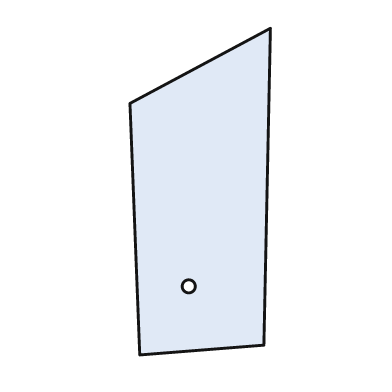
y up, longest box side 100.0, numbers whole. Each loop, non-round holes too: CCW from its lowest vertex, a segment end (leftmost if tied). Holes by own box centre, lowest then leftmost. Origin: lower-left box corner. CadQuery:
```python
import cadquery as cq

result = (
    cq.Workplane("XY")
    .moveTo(3.0, 0.0)
    .lineTo(41.0, 3.0)
    .lineTo(43.0, 100.0)
    .lineTo(0.0, 77.0)
    .close()
    .moveTo(18.0, 21.0)
    .circle(2.0)
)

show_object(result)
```